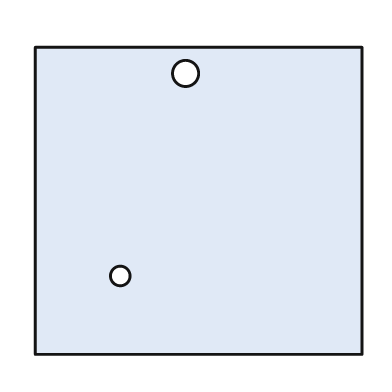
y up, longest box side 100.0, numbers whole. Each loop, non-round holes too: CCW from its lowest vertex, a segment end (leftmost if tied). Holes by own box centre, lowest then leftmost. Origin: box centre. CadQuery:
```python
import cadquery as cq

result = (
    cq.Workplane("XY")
    .moveTo(-50.0, -47.0)
    .lineTo(50.0, -47.0)
    .lineTo(50.0, 47.0)
    .lineTo(-50.0, 47.0)
    .close()
    .moveTo(-24.0, -23.0)
    .circle(3.0)
    .moveTo(-4.0, 39.0)
    .circle(4.0)
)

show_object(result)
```